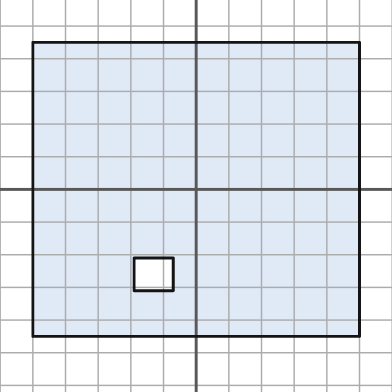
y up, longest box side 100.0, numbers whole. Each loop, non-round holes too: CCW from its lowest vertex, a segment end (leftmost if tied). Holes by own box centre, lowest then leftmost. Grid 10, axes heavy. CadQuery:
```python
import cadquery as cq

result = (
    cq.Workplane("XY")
    .moveTo(-50.0, -45.0)
    .lineTo(50.0, -45.0)
    .lineTo(50.0, 45.0)
    .lineTo(-50.0, 45.0)
    .close()
    .moveTo(-19.0, -31.0)
    .lineTo(-7.0, -31.0)
    .lineTo(-7.0, -21.0)
    .lineTo(-19.0, -21.0)
    .close()
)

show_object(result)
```